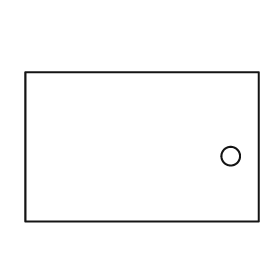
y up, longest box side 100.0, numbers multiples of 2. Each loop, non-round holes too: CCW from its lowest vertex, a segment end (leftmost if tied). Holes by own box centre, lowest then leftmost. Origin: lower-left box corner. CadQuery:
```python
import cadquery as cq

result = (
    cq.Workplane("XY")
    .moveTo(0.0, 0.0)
    .lineTo(100.0, 0.0)
    .lineTo(100.0, 64.0)
    .lineTo(0.0, 64.0)
    .close()
    .moveTo(88.0, 28.0)
    .circle(4.0)
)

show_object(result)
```